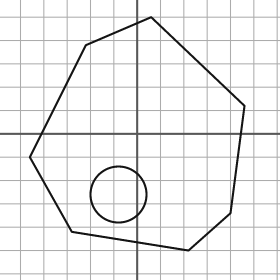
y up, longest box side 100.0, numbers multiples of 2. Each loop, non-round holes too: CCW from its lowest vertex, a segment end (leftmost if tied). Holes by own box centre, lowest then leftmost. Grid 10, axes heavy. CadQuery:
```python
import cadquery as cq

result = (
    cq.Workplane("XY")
    .moveTo(22.0, -50.0)
    .lineTo(40.0, -34.0)
    .lineTo(46.0, 12.0)
    .lineTo(6.0, 50.0)
    .lineTo(-22.0, 38.0)
    .lineTo(-46.0, -10.0)
    .lineTo(-28.0, -42.0)
    .close()
    .moveTo(-8.0, -26.0)
    .circle(12.0)
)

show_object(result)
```